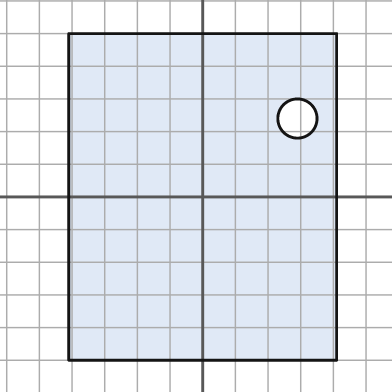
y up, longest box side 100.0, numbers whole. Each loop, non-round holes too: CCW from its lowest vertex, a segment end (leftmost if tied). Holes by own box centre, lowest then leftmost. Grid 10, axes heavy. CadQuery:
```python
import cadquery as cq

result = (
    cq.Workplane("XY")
    .moveTo(-41.0, -50.0)
    .lineTo(41.0, -50.0)
    .lineTo(41.0, 50.0)
    .lineTo(-41.0, 50.0)
    .close()
    .moveTo(29.0, 24.0)
    .circle(6.0)
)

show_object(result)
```